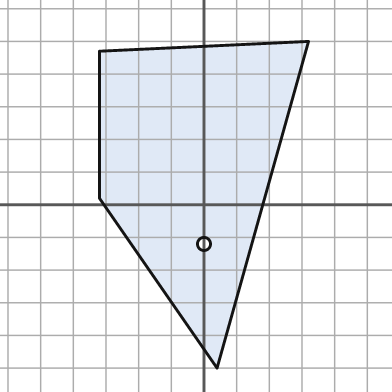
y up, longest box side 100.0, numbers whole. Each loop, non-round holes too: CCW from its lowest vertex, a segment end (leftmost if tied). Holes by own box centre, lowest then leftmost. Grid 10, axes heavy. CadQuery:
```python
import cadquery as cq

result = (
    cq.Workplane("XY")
    .moveTo(4.0, -50.0)
    .lineTo(32.0, 50.0)
    .lineTo(-32.0, 47.0)
    .lineTo(-32.0, 2.0)
    .close()
    .moveTo(0.0, -12.0)
    .circle(2.0)
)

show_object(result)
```